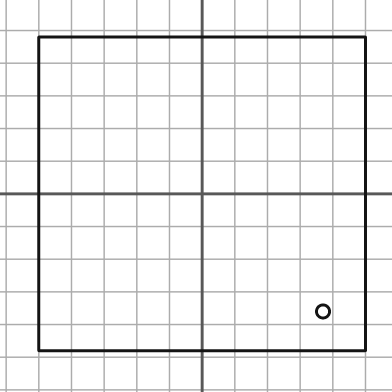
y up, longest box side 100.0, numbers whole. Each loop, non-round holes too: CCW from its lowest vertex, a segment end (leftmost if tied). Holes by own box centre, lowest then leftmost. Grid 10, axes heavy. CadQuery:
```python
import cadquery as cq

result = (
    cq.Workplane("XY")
    .moveTo(-50.0, -48.0)
    .lineTo(50.0, -48.0)
    .lineTo(50.0, 48.0)
    .lineTo(-50.0, 48.0)
    .close()
    .moveTo(37.0, -36.0)
    .circle(2.0)
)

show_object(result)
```